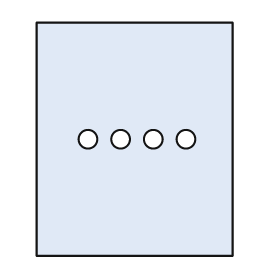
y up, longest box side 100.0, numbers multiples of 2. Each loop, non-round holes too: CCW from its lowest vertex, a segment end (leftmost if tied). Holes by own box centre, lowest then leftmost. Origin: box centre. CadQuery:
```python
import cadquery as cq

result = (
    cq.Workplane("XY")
    .moveTo(-42.0, -50.0)
    .lineTo(42.0, -50.0)
    .lineTo(42.0, 50.0)
    .lineTo(-42.0, 50.0)
    .close()
    .moveTo(-20.0, 0.0)
    .circle(4.0)
    .moveTo(-6.0, 0.0)
    .circle(4.0)
    .moveTo(8.0, 0.0)
    .circle(4.0)
    .moveTo(22.0, 0.0)
    .circle(4.0)
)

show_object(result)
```